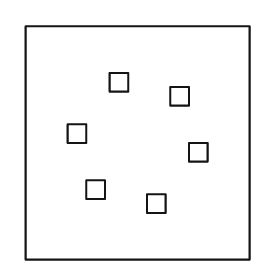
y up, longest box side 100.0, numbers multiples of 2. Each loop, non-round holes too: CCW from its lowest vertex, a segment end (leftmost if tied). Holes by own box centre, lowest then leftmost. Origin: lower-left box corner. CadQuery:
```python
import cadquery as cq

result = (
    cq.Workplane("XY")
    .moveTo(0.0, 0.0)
    .lineTo(96.0, 0.0)
    .lineTo(96.0, 100.0)
    .lineTo(0.0, 100.0)
    .close()
    .moveTo(52.0, 20.0)
    .lineTo(60.0, 20.0)
    .lineTo(60.0, 28.0)
    .lineTo(52.0, 28.0)
    .close()
    .moveTo(26.0, 26.0)
    .lineTo(34.0, 26.0)
    .lineTo(34.0, 34.0)
    .lineTo(26.0, 34.0)
    .close()
    .moveTo(70.0, 42.0)
    .lineTo(78.0, 42.0)
    .lineTo(78.0, 50.0)
    .lineTo(70.0, 50.0)
    .close()
    .moveTo(18.0, 50.0)
    .lineTo(26.0, 50.0)
    .lineTo(26.0, 58.0)
    .lineTo(18.0, 58.0)
    .close()
    .moveTo(62.0, 66.0)
    .lineTo(70.0, 66.0)
    .lineTo(70.0, 74.0)
    .lineTo(62.0, 74.0)
    .close()
    .moveTo(36.0, 72.0)
    .lineTo(44.0, 72.0)
    .lineTo(44.0, 80.0)
    .lineTo(36.0, 80.0)
    .close()
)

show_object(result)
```